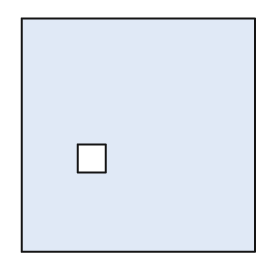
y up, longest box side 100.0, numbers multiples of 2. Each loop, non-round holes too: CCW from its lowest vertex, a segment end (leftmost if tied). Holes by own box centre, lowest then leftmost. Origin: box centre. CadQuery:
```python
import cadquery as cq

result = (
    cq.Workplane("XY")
    .moveTo(-50.0, -50.0)
    .lineTo(50.0, -50.0)
    .lineTo(50.0, 50.0)
    .lineTo(-50.0, 50.0)
    .close()
    .moveTo(-26.0, -16.0)
    .lineTo(-14.0, -16.0)
    .lineTo(-14.0, -4.0)
    .lineTo(-26.0, -4.0)
    .close()
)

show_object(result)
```